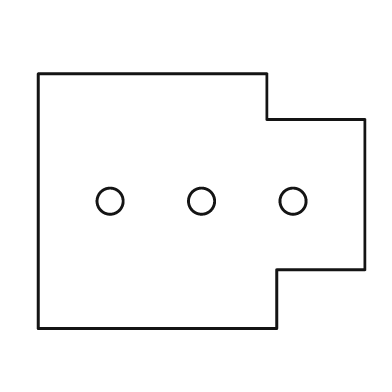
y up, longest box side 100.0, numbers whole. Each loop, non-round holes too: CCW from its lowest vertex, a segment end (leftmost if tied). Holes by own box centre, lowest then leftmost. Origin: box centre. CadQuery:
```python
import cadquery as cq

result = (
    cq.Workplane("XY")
    .moveTo(-50.0, -39.0)
    .lineTo(23.0, -39.0)
    .lineTo(23.0, -21.0)
    .lineTo(50.0, -21.0)
    .lineTo(50.0, 25.0)
    .lineTo(20.0, 25.0)
    .lineTo(20.0, 39.0)
    .lineTo(-50.0, 39.0)
    .close()
    .moveTo(-28.0, 0.0)
    .circle(4.0)
    .moveTo(0.0, 0.0)
    .circle(4.0)
    .moveTo(28.0, 0.0)
    .circle(4.0)
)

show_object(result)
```